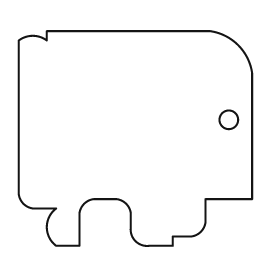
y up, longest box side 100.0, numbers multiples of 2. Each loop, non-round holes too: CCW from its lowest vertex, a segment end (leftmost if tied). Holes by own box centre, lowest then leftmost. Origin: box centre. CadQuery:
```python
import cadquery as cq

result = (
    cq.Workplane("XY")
    .moveTo(-34.0, -46.0)
    .lineTo(-24.0, -46.0)
    .lineTo(-24.0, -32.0)
    .threePointArc((-22.0, -28.0), (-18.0, -26.0))
    .lineTo(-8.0, -26.0)
    .threePointArc((-4.0, -28.0), (-2.0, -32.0))
    .lineTo(-2.0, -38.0)
    .threePointArc((0.0, -44.0), (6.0, -46.0))
    .lineTo(16.0, -46.0)
    .lineTo(16.0, -42.0)
    .lineTo(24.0, -42.0)
    .threePointArc((28.0, -40.0), (30.0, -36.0))
    .lineTo(30.0, -26.0)
    .lineTo(50.0, -26.0)
    .lineTo(50.0, 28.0)
    .threePointArc((44.0, 40.0), (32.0, 46.0))
    .lineTo(-38.0, 46.0)
    .lineTo(-38.0, 42.0)
    .threePointArc((-44.0, 44.0), (-50.0, 42.0))
    .lineTo(-50.0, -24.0)
    .threePointArc((-48.0, -28.0), (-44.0, -30.0))
    .lineTo(-34.0, -30.0)
    .threePointArc((-38.0, -38.0), (-34.0, -46.0))
    .close()
    .moveTo(40.0, 8.0)
    .circle(4.0)
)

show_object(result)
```